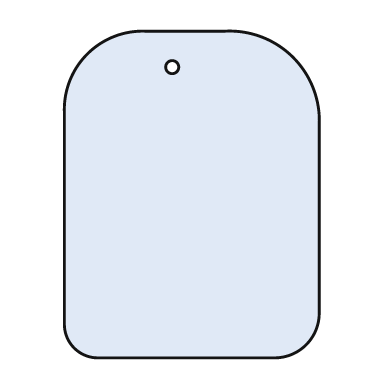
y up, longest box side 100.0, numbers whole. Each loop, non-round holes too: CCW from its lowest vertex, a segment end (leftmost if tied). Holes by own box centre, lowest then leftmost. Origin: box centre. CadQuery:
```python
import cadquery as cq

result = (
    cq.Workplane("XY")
    .moveTo(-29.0, -50.0)
    .lineTo(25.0, -50.0)
    .threePointArc((35.0, -46.0), (39.0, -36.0))
    .lineTo(39.0, 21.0)
    .threePointArc((31.0, 42.0), (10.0, 50.0))
    .lineTo(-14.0, 50.0)
    .threePointArc((-32.0, 43.0), (-39.0, 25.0))
    .lineTo(-39.0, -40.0)
    .threePointArc((-36.0, -47.0), (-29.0, -50.0))
    .close()
    .moveTo(-6.0, 39.0)
    .circle(2.0)
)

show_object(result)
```